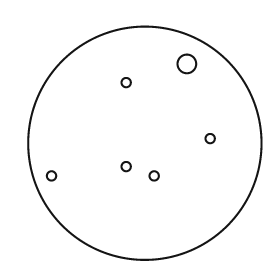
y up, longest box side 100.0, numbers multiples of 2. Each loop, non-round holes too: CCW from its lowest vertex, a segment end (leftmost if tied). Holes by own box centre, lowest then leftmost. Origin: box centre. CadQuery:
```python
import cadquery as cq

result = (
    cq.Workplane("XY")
    .moveTo(0.0, 0.0)
    .circle(50.0)
    .moveTo(-40.0, -14.0)
    .circle(2.0)
    .moveTo(4.0, -14.0)
    .circle(2.0)
    .moveTo(-8.0, -10.0)
    .circle(2.0)
    .moveTo(28.0, 2.0)
    .circle(2.0)
    .moveTo(-8.0, 26.0)
    .circle(2.0)
    .moveTo(18.0, 34.0)
    .circle(4.0)
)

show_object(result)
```